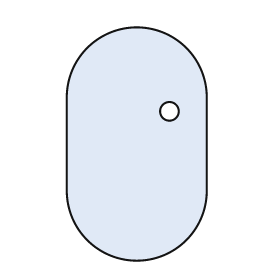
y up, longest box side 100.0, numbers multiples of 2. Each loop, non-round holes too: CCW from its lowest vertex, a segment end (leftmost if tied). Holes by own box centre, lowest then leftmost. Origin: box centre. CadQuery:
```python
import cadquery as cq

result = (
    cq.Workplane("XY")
    .moveTo(-30.0, -20.0)
    .threePointArc((0.0, -50.0), (30.0, -20.0))
    .lineTo(30.0, 20.0)
    .threePointArc((0.0, 50.0), (-30.0, 20.0))
    .close()
    .moveTo(14.0, 14.0)
    .circle(4.0)
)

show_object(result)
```